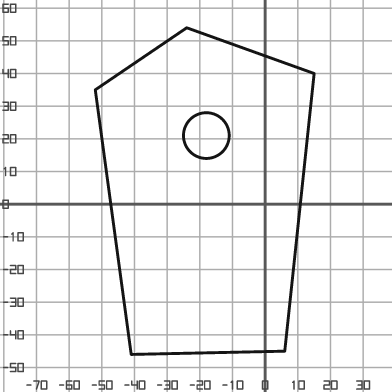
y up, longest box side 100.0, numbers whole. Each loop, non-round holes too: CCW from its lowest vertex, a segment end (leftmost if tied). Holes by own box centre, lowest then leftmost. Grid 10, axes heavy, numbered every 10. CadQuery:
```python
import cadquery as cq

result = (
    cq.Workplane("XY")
    .moveTo(-41.0, -46.0)
    .lineTo(6.0, -45.0)
    .lineTo(15.0, 40.0)
    .lineTo(-24.0, 54.0)
    .lineTo(-52.0, 35.0)
    .close()
    .moveTo(-18.0, 21.0)
    .circle(7.0)
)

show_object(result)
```